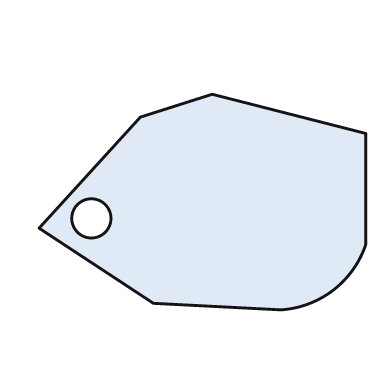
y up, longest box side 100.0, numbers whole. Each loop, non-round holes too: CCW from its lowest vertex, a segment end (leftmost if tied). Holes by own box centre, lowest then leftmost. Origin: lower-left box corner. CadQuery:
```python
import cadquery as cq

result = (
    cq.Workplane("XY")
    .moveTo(74.0, 0.0)
    .threePointArc((90.0, 6.0), (100.0, 20.0))
    .lineTo(100.0, 54.0)
    .lineTo(53.0, 66.0)
    .lineTo(31.0, 59.0)
    .lineTo(0.0, 25.0)
    .lineTo(35.0, 2.0)
    .close()
    .moveTo(16.0, 28.0)
    .circle(6.0)
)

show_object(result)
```